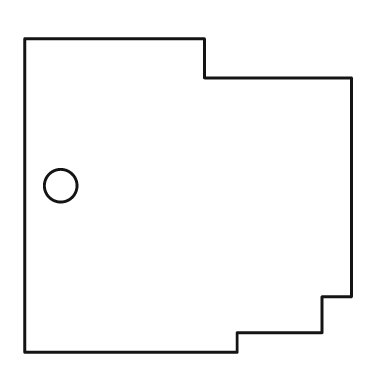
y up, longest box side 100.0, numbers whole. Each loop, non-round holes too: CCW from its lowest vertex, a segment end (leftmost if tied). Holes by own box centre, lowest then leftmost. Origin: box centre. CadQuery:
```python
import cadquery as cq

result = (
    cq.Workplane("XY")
    .moveTo(-50.0, -48.0)
    .lineTo(15.0, -48.0)
    .lineTo(15.0, -42.0)
    .lineTo(41.0, -42.0)
    .lineTo(41.0, -31.0)
    .lineTo(50.0, -31.0)
    .lineTo(50.0, 36.0)
    .lineTo(5.0, 36.0)
    .lineTo(5.0, 48.0)
    .lineTo(-50.0, 48.0)
    .close()
    .moveTo(-39.0, 3.0)
    .circle(5.0)
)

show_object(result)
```